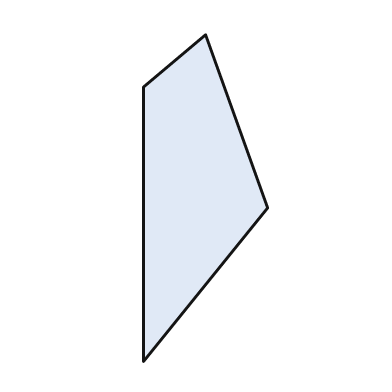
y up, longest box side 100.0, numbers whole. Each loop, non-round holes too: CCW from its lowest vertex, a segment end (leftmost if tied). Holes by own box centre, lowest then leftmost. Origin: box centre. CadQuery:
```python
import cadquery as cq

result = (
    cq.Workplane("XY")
    .moveTo(-19.0, -50.0)
    .lineTo(19.0, -3.0)
    .lineTo(0.0, 50.0)
    .lineTo(-19.0, 34.0)
    .close()
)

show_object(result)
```